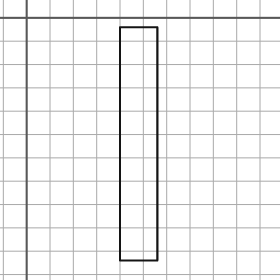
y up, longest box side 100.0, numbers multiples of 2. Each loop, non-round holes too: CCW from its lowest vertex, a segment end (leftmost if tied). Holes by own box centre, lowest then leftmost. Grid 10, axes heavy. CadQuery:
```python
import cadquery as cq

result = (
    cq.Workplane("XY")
    .moveTo(40.0, -104.0)
    .lineTo(56.0, -104.0)
    .lineTo(56.0, -4.0)
    .lineTo(40.0, -4.0)
    .close()
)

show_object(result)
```